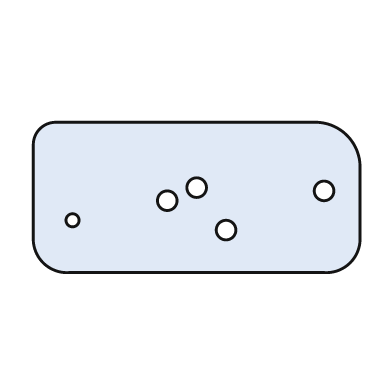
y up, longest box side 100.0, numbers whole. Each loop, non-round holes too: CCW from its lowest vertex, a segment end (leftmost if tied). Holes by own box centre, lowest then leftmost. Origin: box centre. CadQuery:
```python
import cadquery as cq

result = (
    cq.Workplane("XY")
    .moveTo(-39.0, -23.0)
    .lineTo(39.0, -23.0)
    .threePointArc((47.0, -20.0), (50.0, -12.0))
    .lineTo(50.0, 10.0)
    .threePointArc((46.0, 19.0), (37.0, 23.0))
    .lineTo(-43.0, 23.0)
    .threePointArc((-48.0, 21.0), (-50.0, 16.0))
    .lineTo(-50.0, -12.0)
    .threePointArc((-47.0, -20.0), (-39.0, -23.0))
    .close()
    .moveTo(9.0, -10.0)
    .circle(3.0)
    .moveTo(-38.0, -7.0)
    .circle(2.0)
    .moveTo(-9.0, -1.0)
    .circle(3.0)
    .moveTo(39.0, 2.0)
    .circle(3.0)
    .moveTo(0.0, 3.0)
    .circle(3.0)
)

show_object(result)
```